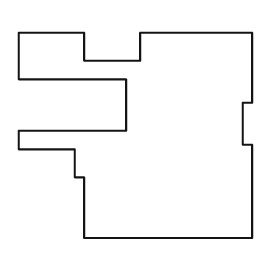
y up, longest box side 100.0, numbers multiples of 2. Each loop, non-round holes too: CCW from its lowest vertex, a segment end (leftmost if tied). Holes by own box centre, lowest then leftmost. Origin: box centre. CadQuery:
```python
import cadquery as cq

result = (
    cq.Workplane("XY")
    .moveTo(-22.0, -44.0)
    .lineTo(50.0, -44.0)
    .lineTo(50.0, -4.0)
    .lineTo(46.0, -4.0)
    .lineTo(46.0, 14.0)
    .lineTo(50.0, 14.0)
    .lineTo(50.0, 44.0)
    .lineTo(2.0, 44.0)
    .lineTo(2.0, 32.0)
    .lineTo(-22.0, 32.0)
    .lineTo(-22.0, 44.0)
    .lineTo(-50.0, 44.0)
    .lineTo(-50.0, 24.0)
    .lineTo(-4.0, 24.0)
    .lineTo(-4.0, 2.0)
    .lineTo(-50.0, 2.0)
    .lineTo(-50.0, -6.0)
    .lineTo(-26.0, -6.0)
    .lineTo(-26.0, -18.0)
    .lineTo(-22.0, -18.0)
    .close()
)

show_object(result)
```